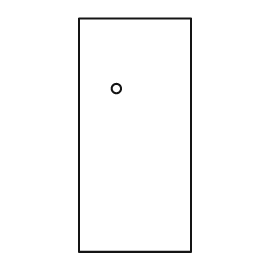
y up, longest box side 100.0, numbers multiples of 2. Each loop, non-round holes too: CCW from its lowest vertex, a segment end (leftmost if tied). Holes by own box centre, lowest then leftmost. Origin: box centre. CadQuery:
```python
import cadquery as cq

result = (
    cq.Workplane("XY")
    .moveTo(-24.0, -50.0)
    .lineTo(24.0, -50.0)
    .lineTo(24.0, 50.0)
    .lineTo(-24.0, 50.0)
    .close()
    .moveTo(-8.0, 20.0)
    .circle(2.0)
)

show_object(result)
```